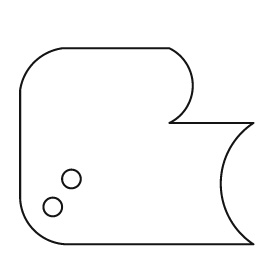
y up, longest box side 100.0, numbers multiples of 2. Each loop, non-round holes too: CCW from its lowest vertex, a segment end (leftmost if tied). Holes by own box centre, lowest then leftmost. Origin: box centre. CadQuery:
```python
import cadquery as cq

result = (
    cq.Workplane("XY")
    .moveTo(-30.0, -42.0)
    .lineTo(50.0, -42.0)
    .threePointArc((36.0, -16.0), (50.0, 10.0))
    .lineTo(14.0, 10.0)
    .threePointArc((24.0, 26.0), (14.0, 42.0))
    .lineTo(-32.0, 42.0)
    .threePointArc((-44.0, 36.0), (-50.0, 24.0))
    .lineTo(-50.0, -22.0)
    .threePointArc((-44.0, -36.0), (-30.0, -42.0))
    .close()
    .moveTo(-36.0, -26.0)
    .circle(4.0)
    .moveTo(-28.0, -14.0)
    .circle(4.0)
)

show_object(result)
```